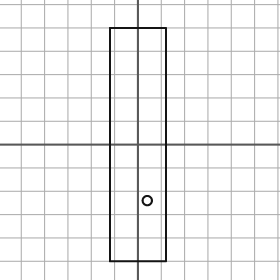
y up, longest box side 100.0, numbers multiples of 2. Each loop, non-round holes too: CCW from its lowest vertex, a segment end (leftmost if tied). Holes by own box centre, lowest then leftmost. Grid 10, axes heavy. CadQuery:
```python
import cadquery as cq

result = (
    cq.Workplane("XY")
    .moveTo(-12.0, -50.0)
    .lineTo(12.0, -50.0)
    .lineTo(12.0, 50.0)
    .lineTo(-12.0, 50.0)
    .close()
    .moveTo(4.0, -24.0)
    .circle(2.0)
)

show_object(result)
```